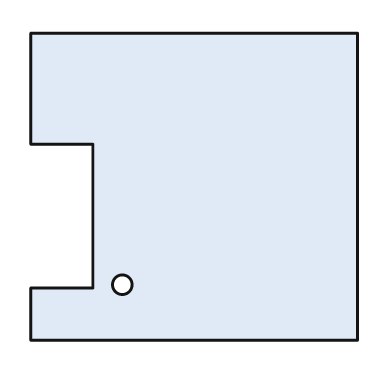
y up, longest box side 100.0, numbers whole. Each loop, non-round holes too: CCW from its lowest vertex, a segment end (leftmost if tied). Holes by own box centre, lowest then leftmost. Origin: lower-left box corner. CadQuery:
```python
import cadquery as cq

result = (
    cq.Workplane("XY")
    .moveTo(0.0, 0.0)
    .lineTo(100.0, 0.0)
    .lineTo(100.0, 94.0)
    .lineTo(0.0, 94.0)
    .lineTo(0.0, 60.0)
    .lineTo(19.0, 60.0)
    .lineTo(19.0, 16.0)
    .lineTo(0.0, 16.0)
    .close()
    .moveTo(28.0, 17.0)
    .circle(3.0)
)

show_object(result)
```